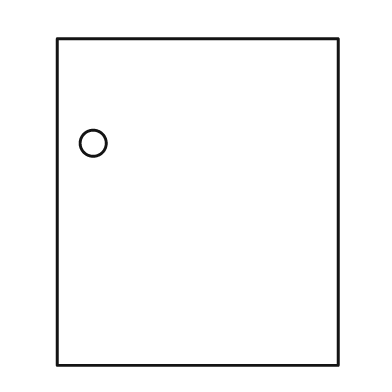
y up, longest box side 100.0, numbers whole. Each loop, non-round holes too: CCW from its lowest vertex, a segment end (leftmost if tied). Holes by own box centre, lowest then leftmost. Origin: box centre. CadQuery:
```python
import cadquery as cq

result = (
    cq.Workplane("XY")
    .moveTo(-43.0, -50.0)
    .lineTo(43.0, -50.0)
    .lineTo(43.0, 50.0)
    .lineTo(-43.0, 50.0)
    .close()
    .moveTo(-32.0, 18.0)
    .circle(4.0)
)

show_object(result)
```